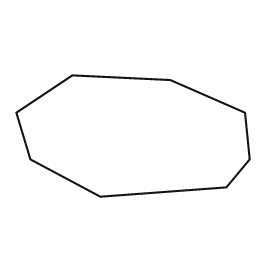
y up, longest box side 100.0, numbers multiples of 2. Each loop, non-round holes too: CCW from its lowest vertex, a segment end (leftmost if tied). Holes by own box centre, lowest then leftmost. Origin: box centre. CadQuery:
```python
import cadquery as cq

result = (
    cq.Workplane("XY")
    .moveTo(-14.0, -26.0)
    .lineTo(40.0, -22.0)
    .lineTo(50.0, -10.0)
    .lineTo(48.0, 10.0)
    .lineTo(16.0, 24.0)
    .lineTo(-26.0, 26.0)
    .lineTo(-50.0, 10.0)
    .lineTo(-44.0, -10.0)
    .close()
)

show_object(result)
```